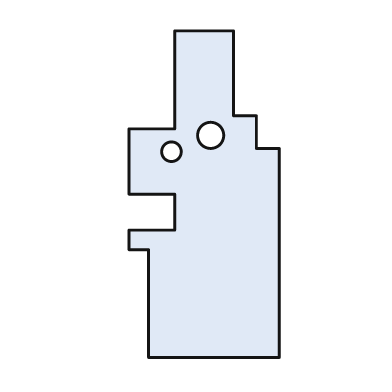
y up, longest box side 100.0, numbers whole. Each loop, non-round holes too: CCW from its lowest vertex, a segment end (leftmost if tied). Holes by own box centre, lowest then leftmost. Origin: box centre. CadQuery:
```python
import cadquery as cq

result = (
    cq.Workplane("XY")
    .moveTo(-17.0, -50.0)
    .lineTo(23.0, -50.0)
    .lineTo(23.0, 14.0)
    .lineTo(16.0, 14.0)
    .lineTo(16.0, 24.0)
    .lineTo(9.0, 24.0)
    .lineTo(9.0, 50.0)
    .lineTo(-9.0, 50.0)
    .lineTo(-9.0, 20.0)
    .lineTo(-23.0, 20.0)
    .lineTo(-23.0, 0.0)
    .lineTo(-9.0, 0.0)
    .lineTo(-9.0, -11.0)
    .lineTo(-23.0, -11.0)
    .lineTo(-23.0, -17.0)
    .lineTo(-17.0, -17.0)
    .close()
    .moveTo(-10.0, 13.0)
    .circle(3.0)
    .moveTo(2.0, 18.0)
    .circle(4.0)
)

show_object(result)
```